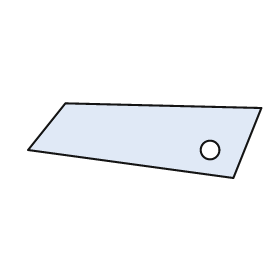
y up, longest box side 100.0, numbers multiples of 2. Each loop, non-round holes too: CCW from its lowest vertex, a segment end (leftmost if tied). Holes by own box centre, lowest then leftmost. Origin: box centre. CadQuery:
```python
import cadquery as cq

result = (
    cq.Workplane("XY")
    .moveTo(38.0, -16.0)
    .lineTo(50.0, 14.0)
    .lineTo(-34.0, 16.0)
    .lineTo(-50.0, -4.0)
    .close()
    .moveTo(28.0, -4.0)
    .circle(4.0)
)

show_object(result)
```